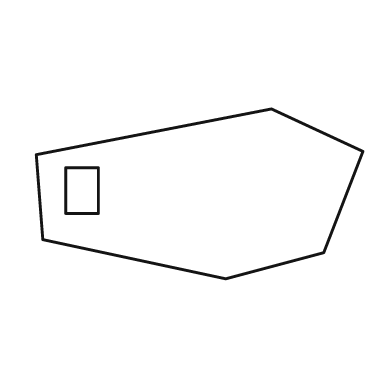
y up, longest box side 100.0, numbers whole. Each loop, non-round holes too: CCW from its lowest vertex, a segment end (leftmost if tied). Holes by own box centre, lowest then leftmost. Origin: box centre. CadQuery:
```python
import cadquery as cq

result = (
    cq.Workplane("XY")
    .moveTo(8.0, -26.0)
    .lineTo(38.0, -18.0)
    .lineTo(50.0, 13.0)
    .lineTo(22.0, 26.0)
    .lineTo(-50.0, 12.0)
    .lineTo(-48.0, -14.0)
    .close()
    .moveTo(-41.0, -6.0)
    .lineTo(-31.0, -6.0)
    .lineTo(-31.0, 8.0)
    .lineTo(-41.0, 8.0)
    .close()
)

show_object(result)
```